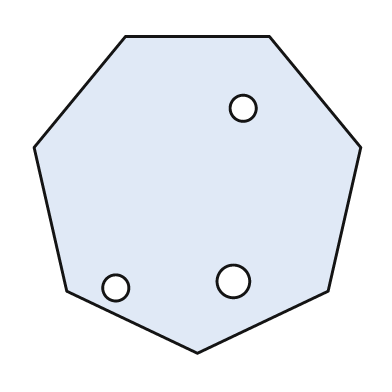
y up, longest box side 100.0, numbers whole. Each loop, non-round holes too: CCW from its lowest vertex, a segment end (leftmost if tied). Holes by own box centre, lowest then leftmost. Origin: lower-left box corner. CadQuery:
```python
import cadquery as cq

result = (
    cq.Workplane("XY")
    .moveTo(50.0, 0.0)
    .lineTo(90.0, 19.0)
    .lineTo(100.0, 63.0)
    .lineTo(72.0, 97.0)
    .lineTo(28.0, 97.0)
    .lineTo(0.0, 63.0)
    .lineTo(10.0, 19.0)
    .close()
    .moveTo(25.0, 20.0)
    .circle(4.0)
    .moveTo(61.0, 22.0)
    .circle(5.0)
    .moveTo(64.0, 75.0)
    .circle(4.0)
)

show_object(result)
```